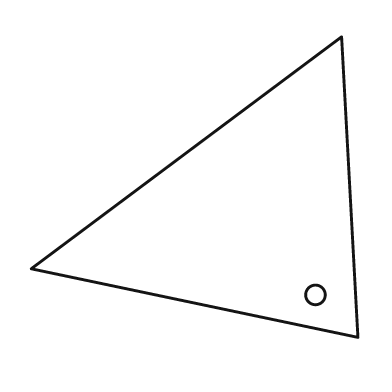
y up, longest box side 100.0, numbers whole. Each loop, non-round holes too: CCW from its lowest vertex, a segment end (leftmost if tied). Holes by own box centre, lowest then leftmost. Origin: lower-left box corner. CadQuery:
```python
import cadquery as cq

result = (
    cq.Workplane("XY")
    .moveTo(100.0, 0.0)
    .lineTo(95.0, 92.0)
    .lineTo(0.0, 21.0)
    .close()
    .moveTo(87.0, 13.0)
    .circle(3.0)
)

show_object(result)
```